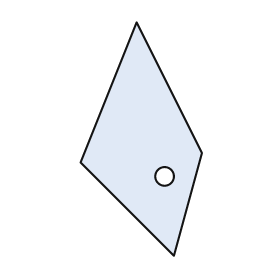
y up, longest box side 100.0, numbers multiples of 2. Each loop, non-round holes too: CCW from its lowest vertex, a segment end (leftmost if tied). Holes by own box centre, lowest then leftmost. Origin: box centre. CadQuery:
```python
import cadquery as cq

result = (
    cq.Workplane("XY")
    .moveTo(14.0, -50.0)
    .lineTo(26.0, -6.0)
    .lineTo(-2.0, 50.0)
    .lineTo(-26.0, -10.0)
    .close()
    .moveTo(10.0, -16.0)
    .circle(4.0)
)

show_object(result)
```